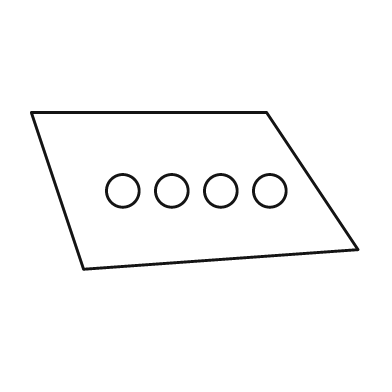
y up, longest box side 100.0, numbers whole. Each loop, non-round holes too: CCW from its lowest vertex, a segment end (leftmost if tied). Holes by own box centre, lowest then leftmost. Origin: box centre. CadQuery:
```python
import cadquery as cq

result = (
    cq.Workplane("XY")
    .moveTo(-34.0, -24.0)
    .lineTo(50.0, -18.0)
    .lineTo(22.0, 24.0)
    .lineTo(-50.0, 24.0)
    .close()
    .moveTo(-22.0, 0.0)
    .circle(5.0)
    .moveTo(-7.0, 0.0)
    .circle(5.0)
    .moveTo(8.0, 0.0)
    .circle(5.0)
    .moveTo(23.0, 0.0)
    .circle(5.0)
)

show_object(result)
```